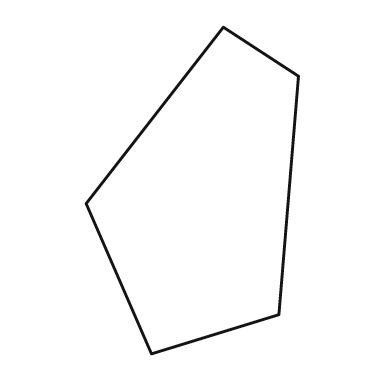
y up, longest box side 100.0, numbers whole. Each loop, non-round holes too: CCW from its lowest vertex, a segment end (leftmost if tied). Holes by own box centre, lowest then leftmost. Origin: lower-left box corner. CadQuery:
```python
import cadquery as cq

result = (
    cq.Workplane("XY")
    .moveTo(20.0, 0.0)
    .lineTo(59.0, 12.0)
    .lineTo(65.0, 85.0)
    .lineTo(42.0, 100.0)
    .lineTo(0.0, 46.0)
    .close()
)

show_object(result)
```